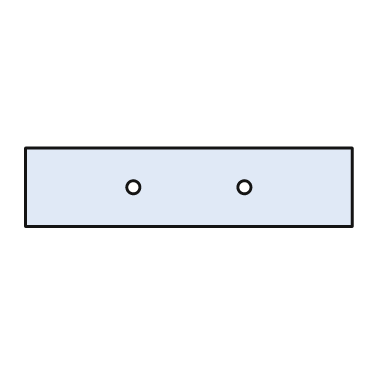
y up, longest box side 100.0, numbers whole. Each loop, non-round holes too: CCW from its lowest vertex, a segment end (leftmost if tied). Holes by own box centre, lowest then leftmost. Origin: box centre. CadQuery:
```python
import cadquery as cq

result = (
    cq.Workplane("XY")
    .moveTo(-50.0, -12.0)
    .lineTo(50.0, -12.0)
    .lineTo(50.0, 12.0)
    .lineTo(-50.0, 12.0)
    .close()
    .moveTo(-17.0, 0.0)
    .circle(2.0)
    .moveTo(17.0, 0.0)
    .circle(2.0)
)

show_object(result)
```